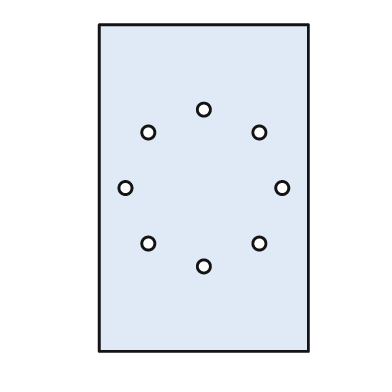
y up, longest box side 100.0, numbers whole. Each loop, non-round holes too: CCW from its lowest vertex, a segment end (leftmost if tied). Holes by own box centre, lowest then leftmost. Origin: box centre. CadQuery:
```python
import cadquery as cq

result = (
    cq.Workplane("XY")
    .moveTo(-32.0, -50.0)
    .lineTo(32.0, -50.0)
    .lineTo(32.0, 50.0)
    .lineTo(-32.0, 50.0)
    .close()
    .moveTo(0.0, -24.0)
    .circle(2.0)
    .moveTo(-17.0, -17.0)
    .circle(2.0)
    .moveTo(17.0, -17.0)
    .circle(2.0)
    .moveTo(-24.0, 0.0)
    .circle(2.0)
    .moveTo(24.0, 0.0)
    .circle(2.0)
    .moveTo(-17.0, 17.0)
    .circle(2.0)
    .moveTo(17.0, 17.0)
    .circle(2.0)
    .moveTo(0.0, 24.0)
    .circle(2.0)
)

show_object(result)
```